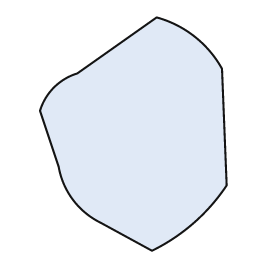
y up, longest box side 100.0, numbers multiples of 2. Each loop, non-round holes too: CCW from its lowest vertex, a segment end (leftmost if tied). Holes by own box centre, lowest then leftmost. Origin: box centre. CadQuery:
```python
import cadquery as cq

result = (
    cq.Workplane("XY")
    .moveTo(8.0, -50.0)
    .threePointArc((26.0, -38.0), (40.0, -22.0))
    .lineTo(38.0, 28.0)
    .threePointArc((26.0, 42.0), (10.0, 50.0))
    .lineTo(-24.0, 26.0)
    .threePointArc((-34.0, 20.0), (-40.0, 10.0))
    .lineTo(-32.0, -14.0)
    .threePointArc((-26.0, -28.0), (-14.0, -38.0))
    .close()
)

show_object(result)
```